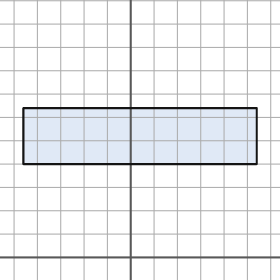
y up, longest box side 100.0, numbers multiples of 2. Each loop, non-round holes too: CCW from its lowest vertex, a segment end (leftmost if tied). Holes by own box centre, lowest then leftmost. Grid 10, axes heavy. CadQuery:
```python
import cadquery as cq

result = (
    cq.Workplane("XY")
    .moveTo(-46.0, 40.0)
    .lineTo(54.0, 40.0)
    .lineTo(54.0, 64.0)
    .lineTo(-46.0, 64.0)
    .close()
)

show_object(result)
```